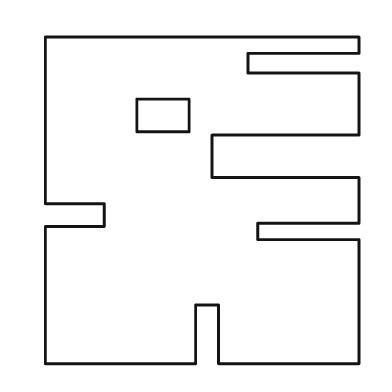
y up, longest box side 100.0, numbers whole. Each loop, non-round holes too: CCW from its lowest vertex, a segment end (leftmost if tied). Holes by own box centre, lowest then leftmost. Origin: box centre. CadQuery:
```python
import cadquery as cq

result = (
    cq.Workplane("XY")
    .moveTo(-48.0, -50.0)
    .lineTo(-2.0, -50.0)
    .lineTo(-2.0, -32.0)
    .lineTo(5.0, -32.0)
    .lineTo(5.0, -50.0)
    .lineTo(48.0, -50.0)
    .lineTo(48.0, -12.0)
    .lineTo(17.0, -12.0)
    .lineTo(17.0, -7.0)
    .lineTo(48.0, -7.0)
    .lineTo(48.0, 7.0)
    .lineTo(3.0, 7.0)
    .lineTo(3.0, 20.0)
    .lineTo(48.0, 20.0)
    .lineTo(48.0, 39.0)
    .lineTo(14.0, 39.0)
    .lineTo(14.0, 45.0)
    .lineTo(48.0, 45.0)
    .lineTo(48.0, 50.0)
    .lineTo(-48.0, 50.0)
    .lineTo(-48.0, -1.0)
    .lineTo(-30.0, -1.0)
    .lineTo(-30.0, -8.0)
    .lineTo(-48.0, -8.0)
    .close()
    .moveTo(-20.0, 21.0)
    .lineTo(-4.0, 21.0)
    .lineTo(-4.0, 31.0)
    .lineTo(-20.0, 31.0)
    .close()
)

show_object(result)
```